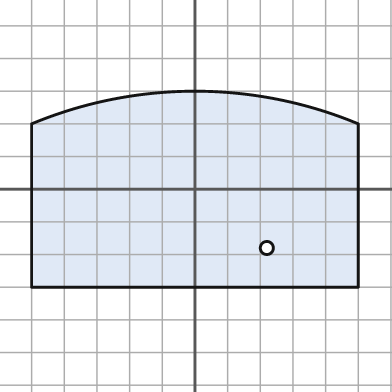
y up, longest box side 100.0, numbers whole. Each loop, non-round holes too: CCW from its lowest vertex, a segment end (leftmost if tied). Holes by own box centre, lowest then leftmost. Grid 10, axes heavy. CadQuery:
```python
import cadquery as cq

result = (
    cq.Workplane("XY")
    .moveTo(-50.0, -30.0)
    .lineTo(50.0, -30.0)
    .lineTo(50.0, 20.0)
    .threePointArc((0.0, 30.0), (-50.0, 20.0))
    .close()
    .moveTo(22.0, -18.0)
    .circle(2.0)
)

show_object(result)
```